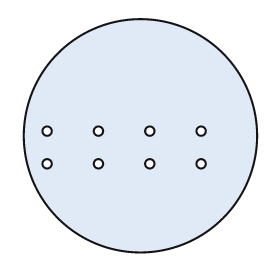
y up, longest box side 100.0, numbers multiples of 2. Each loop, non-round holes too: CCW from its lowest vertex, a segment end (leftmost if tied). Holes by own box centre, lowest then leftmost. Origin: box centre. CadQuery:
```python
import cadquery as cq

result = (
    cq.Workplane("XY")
    .moveTo(0.0, 0.0)
    .circle(50.0)
    .moveTo(-40.0, -12.0)
    .circle(2.0)
    .moveTo(-18.0, -12.0)
    .circle(2.0)
    .moveTo(4.0, -12.0)
    .circle(2.0)
    .moveTo(26.0, -12.0)
    .circle(2.0)
    .moveTo(-40.0, 2.0)
    .circle(2.0)
    .moveTo(-18.0, 2.0)
    .circle(2.0)
    .moveTo(4.0, 2.0)
    .circle(2.0)
    .moveTo(26.0, 2.0)
    .circle(2.0)
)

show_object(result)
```